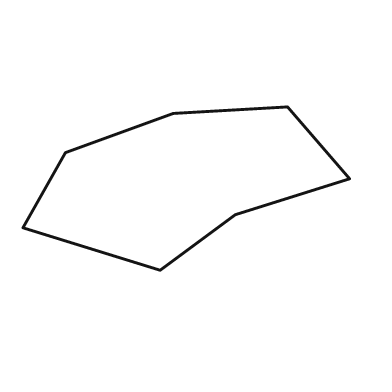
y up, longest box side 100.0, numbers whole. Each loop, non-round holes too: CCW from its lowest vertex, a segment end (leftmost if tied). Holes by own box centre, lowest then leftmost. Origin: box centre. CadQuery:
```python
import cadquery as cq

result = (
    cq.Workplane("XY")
    .moveTo(-8.0, -25.0)
    .lineTo(15.0, -8.0)
    .lineTo(50.0, 3.0)
    .lineTo(31.0, 25.0)
    .lineTo(-4.0, 23.0)
    .lineTo(-37.0, 11.0)
    .lineTo(-50.0, -12.0)
    .close()
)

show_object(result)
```